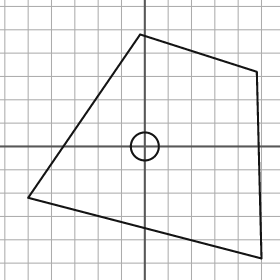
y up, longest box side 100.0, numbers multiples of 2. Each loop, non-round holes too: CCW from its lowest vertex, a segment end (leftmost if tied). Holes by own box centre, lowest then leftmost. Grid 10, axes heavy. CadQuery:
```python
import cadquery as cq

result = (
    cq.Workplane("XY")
    .moveTo(50.0, -48.0)
    .lineTo(48.0, 32.0)
    .lineTo(-2.0, 48.0)
    .lineTo(-50.0, -22.0)
    .close()
    .moveTo(0.0, 0.0)
    .circle(6.0)
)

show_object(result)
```